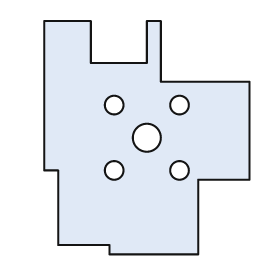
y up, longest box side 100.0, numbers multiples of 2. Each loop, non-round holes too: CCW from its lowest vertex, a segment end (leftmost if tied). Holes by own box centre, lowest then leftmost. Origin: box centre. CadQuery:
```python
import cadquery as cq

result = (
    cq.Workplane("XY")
    .moveTo(-16.0, -50.0)
    .lineTo(22.0, -50.0)
    .lineTo(22.0, -18.0)
    .lineTo(44.0, -18.0)
    .lineTo(44.0, 24.0)
    .lineTo(6.0, 24.0)
    .lineTo(6.0, 50.0)
    .lineTo(0.0, 50.0)
    .lineTo(0.0, 32.0)
    .lineTo(-24.0, 32.0)
    .lineTo(-24.0, 50.0)
    .lineTo(-44.0, 50.0)
    .lineTo(-44.0, -14.0)
    .lineTo(-38.0, -14.0)
    .lineTo(-38.0, -46.0)
    .lineTo(-16.0, -46.0)
    .close()
    .moveTo(-14.0, -14.0)
    .circle(4.0)
    .moveTo(14.0, -14.0)
    .circle(4.0)
    .moveTo(0.0, 0.0)
    .circle(6.0)
    .moveTo(-14.0, 14.0)
    .circle(4.0)
    .moveTo(14.0, 14.0)
    .circle(4.0)
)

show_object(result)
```